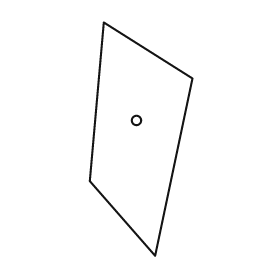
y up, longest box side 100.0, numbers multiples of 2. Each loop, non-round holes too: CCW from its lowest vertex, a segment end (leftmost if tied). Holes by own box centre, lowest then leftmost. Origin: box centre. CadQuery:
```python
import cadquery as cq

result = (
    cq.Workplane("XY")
    .moveTo(6.0, -50.0)
    .lineTo(22.0, 26.0)
    .lineTo(-16.0, 50.0)
    .lineTo(-22.0, -18.0)
    .close()
    .moveTo(-2.0, 8.0)
    .circle(2.0)
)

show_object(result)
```